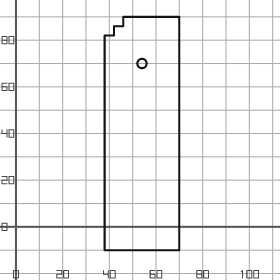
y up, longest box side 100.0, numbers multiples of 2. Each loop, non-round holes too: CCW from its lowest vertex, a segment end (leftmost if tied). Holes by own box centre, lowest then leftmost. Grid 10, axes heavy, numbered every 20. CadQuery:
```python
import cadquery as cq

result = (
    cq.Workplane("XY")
    .moveTo(38.0, -10.0)
    .lineTo(70.0, -10.0)
    .lineTo(70.0, 90.0)
    .lineTo(46.0, 90.0)
    .lineTo(46.0, 86.0)
    .lineTo(42.0, 86.0)
    .lineTo(42.0, 82.0)
    .lineTo(38.0, 82.0)
    .close()
    .moveTo(54.0, 70.0)
    .circle(2.0)
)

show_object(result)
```